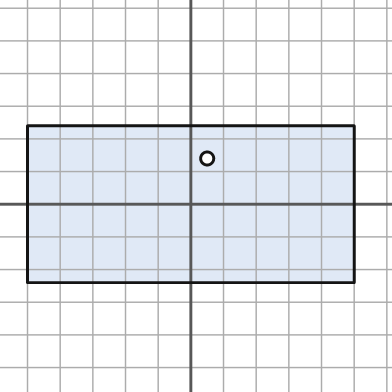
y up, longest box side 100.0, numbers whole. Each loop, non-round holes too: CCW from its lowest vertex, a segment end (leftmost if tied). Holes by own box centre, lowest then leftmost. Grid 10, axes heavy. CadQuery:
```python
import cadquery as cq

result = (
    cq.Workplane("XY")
    .moveTo(-50.0, -24.0)
    .lineTo(50.0, -24.0)
    .lineTo(50.0, 24.0)
    .lineTo(-50.0, 24.0)
    .close()
    .moveTo(5.0, 14.0)
    .circle(2.0)
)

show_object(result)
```